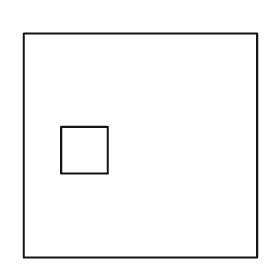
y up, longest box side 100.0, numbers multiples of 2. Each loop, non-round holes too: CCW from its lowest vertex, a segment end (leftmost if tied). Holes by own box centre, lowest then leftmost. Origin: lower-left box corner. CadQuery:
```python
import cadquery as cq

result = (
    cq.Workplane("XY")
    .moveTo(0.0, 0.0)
    .lineTo(100.0, 0.0)
    .lineTo(100.0, 96.0)
    .lineTo(0.0, 96.0)
    .close()
    .moveTo(16.0, 36.0)
    .lineTo(36.0, 36.0)
    .lineTo(36.0, 56.0)
    .lineTo(16.0, 56.0)
    .close()
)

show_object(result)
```